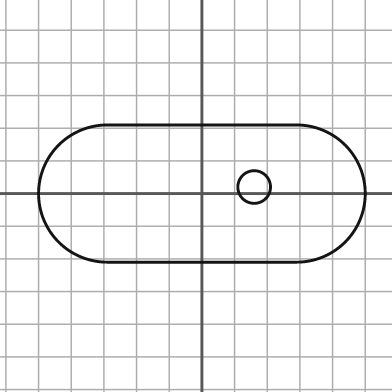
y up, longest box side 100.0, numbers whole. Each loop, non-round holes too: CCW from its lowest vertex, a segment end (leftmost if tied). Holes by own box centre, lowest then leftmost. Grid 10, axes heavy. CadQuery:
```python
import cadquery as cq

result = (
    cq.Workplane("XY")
    .moveTo(-29.0, -21.0)
    .lineTo(29.0, -21.0)
    .threePointArc((50.0, 0.0), (29.0, 21.0))
    .lineTo(-29.0, 21.0)
    .threePointArc((-50.0, 0.0), (-29.0, -21.0))
    .close()
    .moveTo(16.0, 2.0)
    .circle(5.0)
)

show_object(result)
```